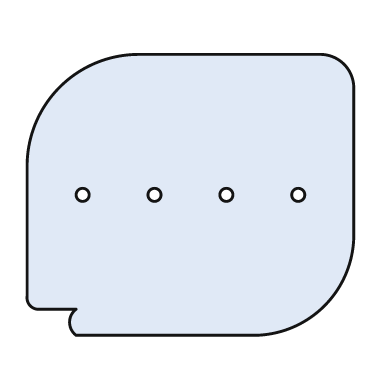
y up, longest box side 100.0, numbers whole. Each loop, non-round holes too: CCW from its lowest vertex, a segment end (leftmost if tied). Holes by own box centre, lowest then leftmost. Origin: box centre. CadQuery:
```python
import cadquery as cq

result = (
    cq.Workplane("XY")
    .moveTo(-35.0, -43.0)
    .lineTo(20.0, -43.0)
    .threePointArc((41.0, -34.0), (50.0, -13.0))
    .lineTo(50.0, 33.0)
    .threePointArc((47.0, 40.0), (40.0, 43.0))
    .lineTo(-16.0, 43.0)
    .threePointArc((-40.0, 33.0), (-50.0, 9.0))
    .lineTo(-50.0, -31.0)
    .threePointArc((-49.0, -34.0), (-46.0, -35.0))
    .lineTo(-35.0, -35.0)
    .threePointArc((-37.0, -39.0), (-35.0, -43.0))
    .close()
    .moveTo(-33.0, 0.0)
    .circle(2.0)
    .moveTo(-11.0, 0.0)
    .circle(2.0)
    .moveTo(11.0, 0.0)
    .circle(2.0)
    .moveTo(33.0, 0.0)
    .circle(2.0)
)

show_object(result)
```